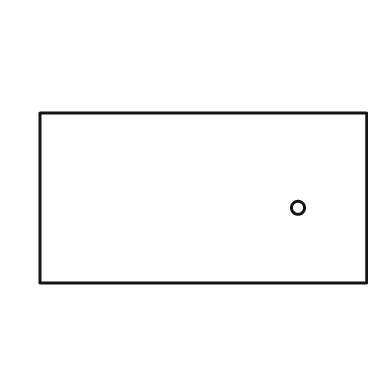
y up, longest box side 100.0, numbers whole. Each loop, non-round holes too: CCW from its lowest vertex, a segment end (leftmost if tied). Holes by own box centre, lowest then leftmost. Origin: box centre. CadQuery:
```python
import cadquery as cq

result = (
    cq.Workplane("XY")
    .moveTo(-50.0, -26.0)
    .lineTo(50.0, -26.0)
    .lineTo(50.0, 26.0)
    .lineTo(-50.0, 26.0)
    .close()
    .moveTo(29.0, -3.0)
    .circle(2.0)
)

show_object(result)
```